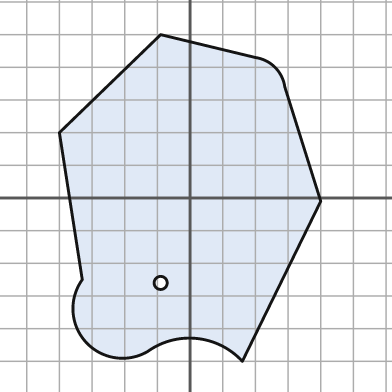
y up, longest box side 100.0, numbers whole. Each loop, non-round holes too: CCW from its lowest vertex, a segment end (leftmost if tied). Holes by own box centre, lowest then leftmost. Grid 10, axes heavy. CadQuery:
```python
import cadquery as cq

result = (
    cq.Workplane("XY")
    .moveTo(16.0, -50.0)
    .lineTo(40.0, -1.0)
    .lineTo(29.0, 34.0)
    .threePointArc((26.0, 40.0), (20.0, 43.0))
    .lineTo(-9.0, 50.0)
    .lineTo(-40.0, 20.0)
    .lineTo(-33.0, -25.0)
    .threePointArc((-32.0, -44.0), (-13.0, -47.0))
    .threePointArc((2.0, -43.0), (16.0, -50.0))
    .close()
    .moveTo(-9.0, -26.0)
    .circle(2.0)
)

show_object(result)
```